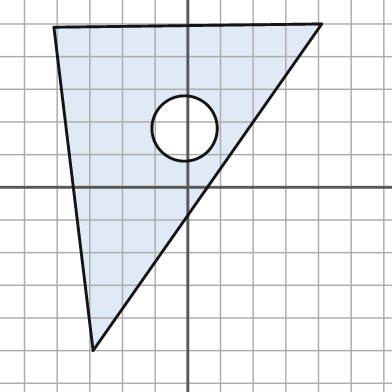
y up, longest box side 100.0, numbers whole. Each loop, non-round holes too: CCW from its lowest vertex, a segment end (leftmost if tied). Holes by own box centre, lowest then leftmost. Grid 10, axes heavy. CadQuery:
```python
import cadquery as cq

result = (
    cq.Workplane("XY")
    .moveTo(-29.0, -50.0)
    .lineTo(41.0, 50.0)
    .lineTo(-41.0, 49.0)
    .close()
    .moveTo(-1.0, 18.0)
    .circle(10.0)
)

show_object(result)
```